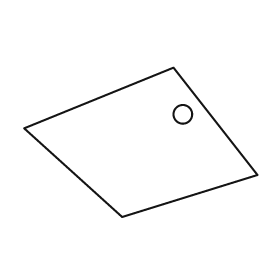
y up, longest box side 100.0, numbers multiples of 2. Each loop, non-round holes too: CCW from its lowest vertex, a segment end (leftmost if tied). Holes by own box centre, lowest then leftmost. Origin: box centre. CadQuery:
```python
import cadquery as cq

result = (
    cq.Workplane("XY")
    .moveTo(-8.0, -32.0)
    .lineTo(50.0, -14.0)
    .lineTo(14.0, 32.0)
    .lineTo(-50.0, 6.0)
    .close()
    .moveTo(18.0, 12.0)
    .circle(4.0)
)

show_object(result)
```